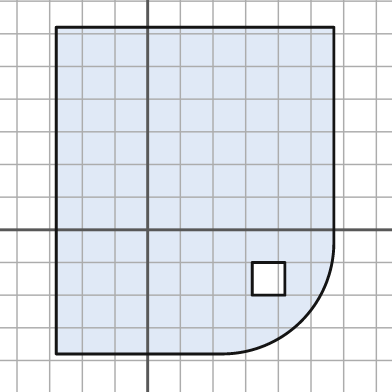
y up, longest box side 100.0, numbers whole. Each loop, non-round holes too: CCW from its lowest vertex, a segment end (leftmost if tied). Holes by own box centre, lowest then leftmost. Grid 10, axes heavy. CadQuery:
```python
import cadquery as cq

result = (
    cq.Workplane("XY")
    .moveTo(-28.0, -38.0)
    .lineTo(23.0, -38.0)
    .threePointArc((47.0, -28.0), (57.0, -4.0))
    .lineTo(57.0, 62.0)
    .lineTo(-28.0, 62.0)
    .close()
    .moveTo(32.0, -20.0)
    .lineTo(42.0, -20.0)
    .lineTo(42.0, -10.0)
    .lineTo(32.0, -10.0)
    .close()
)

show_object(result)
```